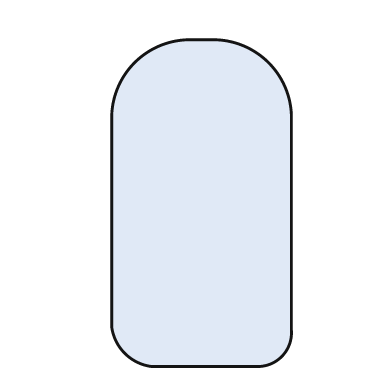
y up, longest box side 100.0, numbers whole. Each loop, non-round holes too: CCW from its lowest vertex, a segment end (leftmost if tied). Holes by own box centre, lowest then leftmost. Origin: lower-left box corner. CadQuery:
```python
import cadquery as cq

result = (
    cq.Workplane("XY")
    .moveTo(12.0, 0.0)
    .lineTo(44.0, 0.0)
    .threePointArc((52.0, 3.0), (55.0, 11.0))
    .lineTo(55.0, 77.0)
    .threePointArc((48.0, 93.0), (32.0, 100.0))
    .lineTo(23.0, 100.0)
    .threePointArc((7.0, 93.0), (0.0, 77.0))
    .lineTo(0.0, 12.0)
    .threePointArc((4.0, 4.0), (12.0, 0.0))
    .close()
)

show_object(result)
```